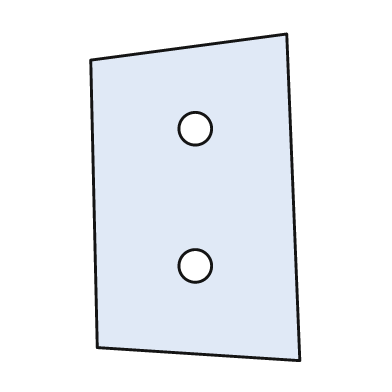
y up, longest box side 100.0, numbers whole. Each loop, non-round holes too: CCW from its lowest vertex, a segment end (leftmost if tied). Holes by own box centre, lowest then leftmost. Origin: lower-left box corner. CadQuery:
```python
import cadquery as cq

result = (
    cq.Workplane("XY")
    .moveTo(64.0, 0.0)
    .lineTo(60.0, 100.0)
    .lineTo(0.0, 92.0)
    .lineTo(2.0, 4.0)
    .close()
    .moveTo(32.0, 29.0)
    .circle(5.0)
    .moveTo(32.0, 71.0)
    .circle(5.0)
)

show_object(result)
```